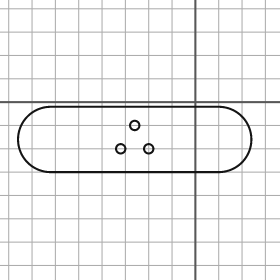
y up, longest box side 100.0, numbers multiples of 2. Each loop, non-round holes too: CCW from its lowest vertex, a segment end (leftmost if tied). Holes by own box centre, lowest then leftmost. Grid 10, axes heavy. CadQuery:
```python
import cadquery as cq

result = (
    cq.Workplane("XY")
    .moveTo(-62.0, -30.0)
    .lineTo(10.0, -30.0)
    .threePointArc((24.0, -16.0), (10.0, -2.0))
    .lineTo(-62.0, -2.0)
    .threePointArc((-76.0, -16.0), (-62.0, -30.0))
    .close()
    .moveTo(-32.0, -20.0)
    .circle(2.0)
    .moveTo(-20.0, -20.0)
    .circle(2.0)
    .moveTo(-26.0, -10.0)
    .circle(2.0)
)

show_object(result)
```